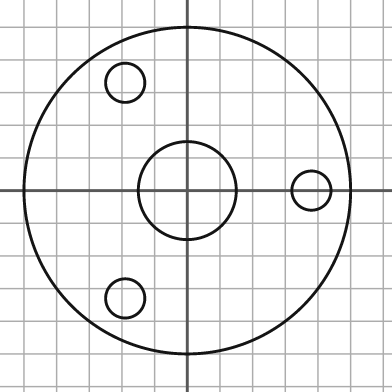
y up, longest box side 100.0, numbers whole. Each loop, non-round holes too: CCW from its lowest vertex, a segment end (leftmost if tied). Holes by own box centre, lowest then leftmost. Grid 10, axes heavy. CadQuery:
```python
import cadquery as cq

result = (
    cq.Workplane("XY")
    .moveTo(0.0, 0.0)
    .circle(50.0)
    .moveTo(-19.0, -33.0)
    .circle(6.0)
    .moveTo(0.0, 0.0)
    .circle(15.0)
    .moveTo(38.0, 0.0)
    .circle(6.0)
    .moveTo(-19.0, 33.0)
    .circle(6.0)
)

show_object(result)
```